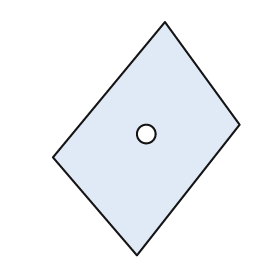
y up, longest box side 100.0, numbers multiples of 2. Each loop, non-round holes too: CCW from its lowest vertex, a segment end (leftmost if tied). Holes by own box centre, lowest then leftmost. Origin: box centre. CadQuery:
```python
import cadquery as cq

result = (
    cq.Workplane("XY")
    .moveTo(-4.0, -50.0)
    .lineTo(40.0, 6.0)
    .lineTo(8.0, 50.0)
    .lineTo(-40.0, -8.0)
    .close()
    .moveTo(0.0, 2.0)
    .circle(4.0)
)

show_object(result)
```